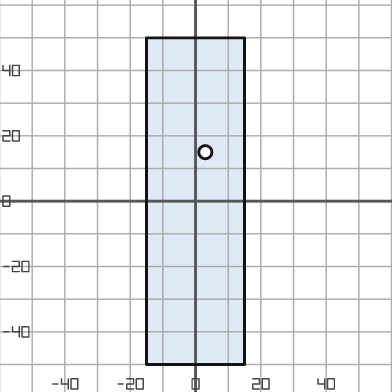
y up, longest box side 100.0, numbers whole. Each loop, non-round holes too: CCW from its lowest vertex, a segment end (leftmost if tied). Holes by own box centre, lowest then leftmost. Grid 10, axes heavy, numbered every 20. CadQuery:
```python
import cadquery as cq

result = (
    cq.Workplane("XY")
    .moveTo(-15.0, -50.0)
    .lineTo(15.0, -50.0)
    .lineTo(15.0, 50.0)
    .lineTo(-15.0, 50.0)
    .close()
    .moveTo(3.0, 15.0)
    .circle(2.0)
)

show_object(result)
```